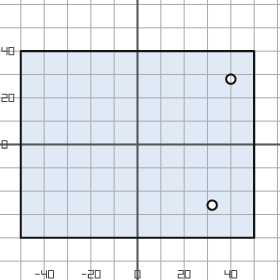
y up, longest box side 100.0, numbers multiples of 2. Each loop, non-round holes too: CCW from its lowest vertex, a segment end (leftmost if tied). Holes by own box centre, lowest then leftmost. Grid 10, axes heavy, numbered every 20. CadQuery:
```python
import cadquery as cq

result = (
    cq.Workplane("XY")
    .moveTo(-50.0, -40.0)
    .lineTo(50.0, -40.0)
    .lineTo(50.0, 40.0)
    .lineTo(-50.0, 40.0)
    .close()
    .moveTo(32.0, -26.0)
    .circle(2.0)
    .moveTo(40.0, 28.0)
    .circle(2.0)
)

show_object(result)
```